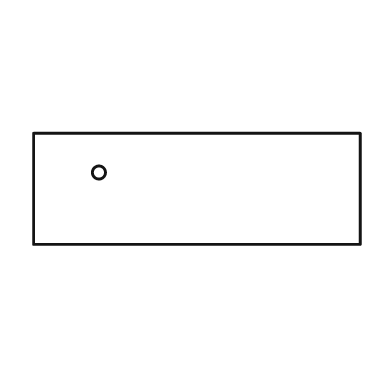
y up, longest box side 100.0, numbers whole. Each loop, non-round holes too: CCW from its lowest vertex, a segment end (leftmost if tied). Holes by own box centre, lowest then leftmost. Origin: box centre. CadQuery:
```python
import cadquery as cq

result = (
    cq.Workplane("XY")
    .moveTo(-50.0, -17.0)
    .lineTo(50.0, -17.0)
    .lineTo(50.0, 17.0)
    .lineTo(-50.0, 17.0)
    .close()
    .moveTo(-30.0, 5.0)
    .circle(2.0)
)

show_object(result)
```